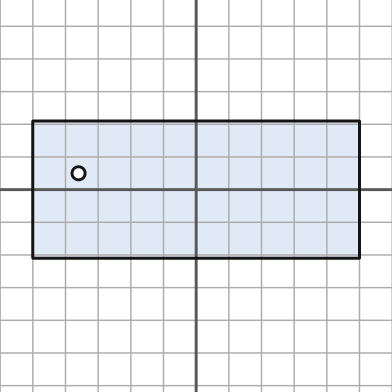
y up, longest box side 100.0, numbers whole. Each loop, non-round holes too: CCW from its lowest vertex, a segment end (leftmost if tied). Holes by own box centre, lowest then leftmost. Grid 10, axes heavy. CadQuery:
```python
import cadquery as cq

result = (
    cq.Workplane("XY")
    .moveTo(-50.0, -21.0)
    .lineTo(50.0, -21.0)
    .lineTo(50.0, 21.0)
    .lineTo(-50.0, 21.0)
    .close()
    .moveTo(-36.0, 5.0)
    .circle(2.0)
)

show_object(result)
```